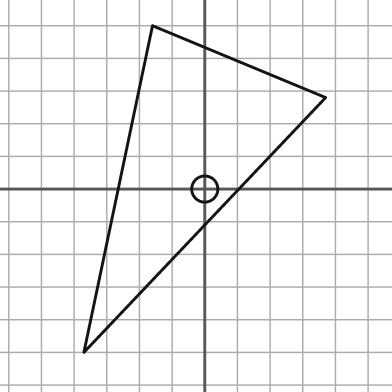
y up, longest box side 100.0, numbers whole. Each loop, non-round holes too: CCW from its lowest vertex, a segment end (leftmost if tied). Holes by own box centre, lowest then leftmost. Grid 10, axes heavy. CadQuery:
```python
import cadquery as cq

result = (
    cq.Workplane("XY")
    .moveTo(-37.0, -50.0)
    .lineTo(37.0, 28.0)
    .lineTo(-16.0, 50.0)
    .close()
    .moveTo(0.0, 0.0)
    .circle(4.0)
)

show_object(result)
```